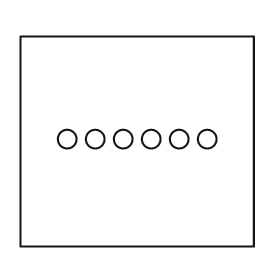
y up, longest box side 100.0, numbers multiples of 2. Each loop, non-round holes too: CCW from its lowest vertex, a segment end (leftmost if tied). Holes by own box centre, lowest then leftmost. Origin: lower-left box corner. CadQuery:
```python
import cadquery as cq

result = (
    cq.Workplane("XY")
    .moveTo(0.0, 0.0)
    .lineTo(100.0, 0.0)
    .lineTo(100.0, 90.0)
    .lineTo(0.0, 90.0)
    .close()
    .moveTo(20.0, 46.0)
    .circle(4.0)
    .moveTo(32.0, 46.0)
    .circle(4.0)
    .moveTo(44.0, 46.0)
    .circle(4.0)
    .moveTo(56.0, 46.0)
    .circle(4.0)
    .moveTo(68.0, 46.0)
    .circle(4.0)
    .moveTo(80.0, 46.0)
    .circle(4.0)
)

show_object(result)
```